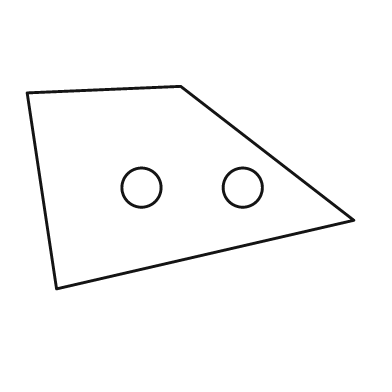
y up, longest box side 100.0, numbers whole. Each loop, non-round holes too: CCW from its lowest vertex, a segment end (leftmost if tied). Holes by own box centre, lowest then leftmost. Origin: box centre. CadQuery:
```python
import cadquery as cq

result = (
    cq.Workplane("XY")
    .moveTo(-41.0, -31.0)
    .lineTo(50.0, -10.0)
    .lineTo(-3.0, 31.0)
    .lineTo(-50.0, 29.0)
    .close()
    .moveTo(-15.0, 0.0)
    .circle(6.0)
    .moveTo(16.0, 0.0)
    .circle(6.0)
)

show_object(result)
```